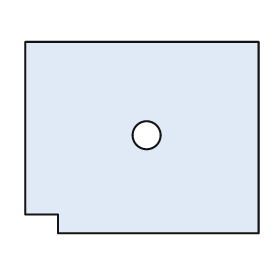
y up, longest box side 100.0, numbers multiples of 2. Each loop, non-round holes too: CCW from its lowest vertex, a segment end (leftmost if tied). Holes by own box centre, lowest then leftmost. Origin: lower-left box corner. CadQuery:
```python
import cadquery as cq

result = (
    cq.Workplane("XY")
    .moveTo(14.0, 0.0)
    .lineTo(100.0, 0.0)
    .lineTo(100.0, 82.0)
    .lineTo(0.0, 82.0)
    .lineTo(0.0, 8.0)
    .lineTo(14.0, 8.0)
    .close()
    .moveTo(52.0, 42.0)
    .circle(6.0)
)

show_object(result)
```